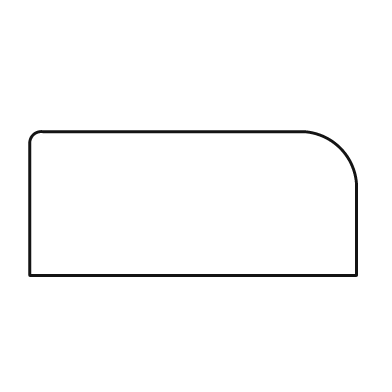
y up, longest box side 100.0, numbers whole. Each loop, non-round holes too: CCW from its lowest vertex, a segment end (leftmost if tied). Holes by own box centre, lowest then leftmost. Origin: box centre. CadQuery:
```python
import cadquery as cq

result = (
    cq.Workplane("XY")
    .moveTo(-50.0, -22.0)
    .lineTo(50.0, -22.0)
    .lineTo(50.0, 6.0)
    .threePointArc((45.0, 17.0), (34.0, 22.0))
    .lineTo(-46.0, 22.0)
    .threePointArc((-49.0, 21.0), (-50.0, 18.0))
    .close()
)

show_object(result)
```